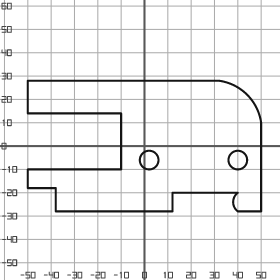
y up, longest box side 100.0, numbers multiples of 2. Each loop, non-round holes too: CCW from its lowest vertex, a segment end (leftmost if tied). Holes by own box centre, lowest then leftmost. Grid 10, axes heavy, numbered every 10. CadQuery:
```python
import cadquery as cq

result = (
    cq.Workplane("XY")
    .moveTo(-38.0, -28.0)
    .lineTo(12.0, -28.0)
    .lineTo(12.0, -20.0)
    .lineTo(40.0, -20.0)
    .threePointArc((38.0, -24.0), (40.0, -28.0))
    .lineTo(50.0, -28.0)
    .lineTo(50.0, 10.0)
    .threePointArc((44.0, 22.0), (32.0, 28.0))
    .lineTo(-50.0, 28.0)
    .lineTo(-50.0, 14.0)
    .lineTo(-10.0, 14.0)
    .lineTo(-10.0, -10.0)
    .lineTo(-50.0, -10.0)
    .lineTo(-50.0, -18.0)
    .lineTo(-38.0, -18.0)
    .close()
    .moveTo(2.0, -6.0)
    .circle(4.0)
    .moveTo(40.0, -6.0)
    .circle(4.0)
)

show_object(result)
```